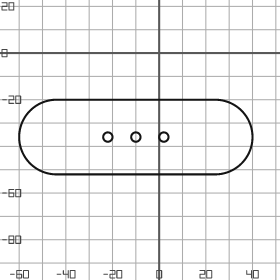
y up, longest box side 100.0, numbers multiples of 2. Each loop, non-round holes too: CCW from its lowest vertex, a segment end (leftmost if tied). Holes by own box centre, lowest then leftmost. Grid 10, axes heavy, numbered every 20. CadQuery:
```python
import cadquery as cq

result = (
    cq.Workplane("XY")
    .moveTo(-44.0, -52.0)
    .lineTo(24.0, -52.0)
    .threePointArc((40.0, -36.0), (24.0, -20.0))
    .lineTo(-44.0, -20.0)
    .threePointArc((-60.0, -36.0), (-44.0, -52.0))
    .close()
    .moveTo(-22.0, -36.0)
    .circle(2.0)
    .moveTo(-10.0, -36.0)
    .circle(2.0)
    .moveTo(2.0, -36.0)
    .circle(2.0)
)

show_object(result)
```